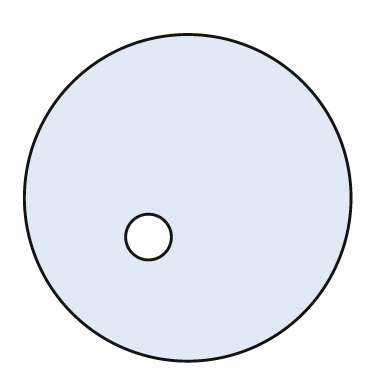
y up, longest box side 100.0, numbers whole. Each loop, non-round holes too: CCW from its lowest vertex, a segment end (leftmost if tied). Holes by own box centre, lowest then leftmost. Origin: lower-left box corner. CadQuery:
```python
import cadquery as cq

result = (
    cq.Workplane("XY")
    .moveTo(50.0, 50.0)
    .circle(50.0)
    .moveTo(38.0, 38.0)
    .circle(7.0)
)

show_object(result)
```